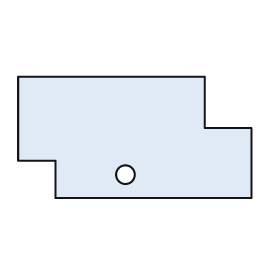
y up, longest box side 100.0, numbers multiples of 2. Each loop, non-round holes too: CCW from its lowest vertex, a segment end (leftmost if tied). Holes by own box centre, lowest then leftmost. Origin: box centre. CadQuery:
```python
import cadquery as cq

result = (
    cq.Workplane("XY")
    .moveTo(-34.0, -26.0)
    .lineTo(50.0, -26.0)
    .lineTo(50.0, 4.0)
    .lineTo(30.0, 4.0)
    .lineTo(30.0, 26.0)
    .lineTo(-50.0, 26.0)
    .lineTo(-50.0, -10.0)
    .lineTo(-34.0, -10.0)
    .close()
    .moveTo(-4.0, -16.0)
    .circle(4.0)
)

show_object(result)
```